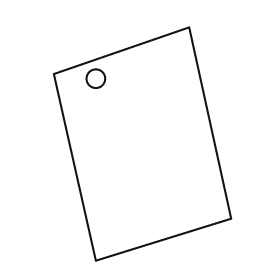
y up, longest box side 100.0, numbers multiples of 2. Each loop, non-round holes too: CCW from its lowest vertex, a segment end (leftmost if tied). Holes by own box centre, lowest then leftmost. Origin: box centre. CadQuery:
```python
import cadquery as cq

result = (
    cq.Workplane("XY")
    .moveTo(-20.0, -50.0)
    .lineTo(38.0, -32.0)
    .lineTo(20.0, 50.0)
    .lineTo(-38.0, 30.0)
    .close()
    .moveTo(-20.0, 28.0)
    .circle(4.0)
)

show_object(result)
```